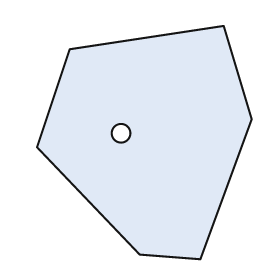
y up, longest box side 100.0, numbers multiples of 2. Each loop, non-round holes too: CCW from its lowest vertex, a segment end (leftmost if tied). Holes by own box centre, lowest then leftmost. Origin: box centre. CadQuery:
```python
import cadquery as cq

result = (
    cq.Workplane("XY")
    .moveTo(24.0, -50.0)
    .lineTo(46.0, 10.0)
    .lineTo(34.0, 50.0)
    .lineTo(-32.0, 40.0)
    .lineTo(-46.0, -2.0)
    .lineTo(-2.0, -48.0)
    .close()
    .moveTo(-10.0, 4.0)
    .circle(4.0)
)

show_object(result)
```